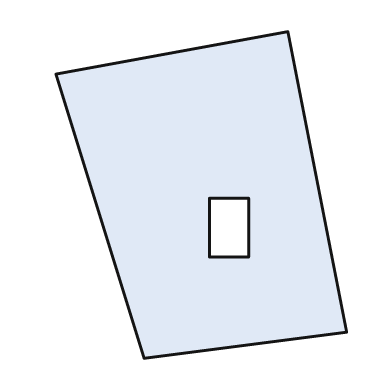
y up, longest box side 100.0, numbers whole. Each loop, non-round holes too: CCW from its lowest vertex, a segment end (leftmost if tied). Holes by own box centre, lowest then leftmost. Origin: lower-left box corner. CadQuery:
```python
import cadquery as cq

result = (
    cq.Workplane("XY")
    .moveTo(27.0, 0.0)
    .lineTo(89.0, 8.0)
    .lineTo(71.0, 100.0)
    .lineTo(0.0, 87.0)
    .close()
    .moveTo(47.0, 31.0)
    .lineTo(59.0, 31.0)
    .lineTo(59.0, 49.0)
    .lineTo(47.0, 49.0)
    .close()
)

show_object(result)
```